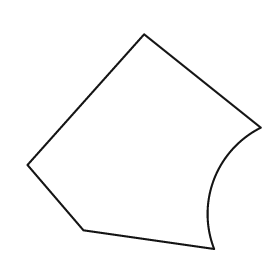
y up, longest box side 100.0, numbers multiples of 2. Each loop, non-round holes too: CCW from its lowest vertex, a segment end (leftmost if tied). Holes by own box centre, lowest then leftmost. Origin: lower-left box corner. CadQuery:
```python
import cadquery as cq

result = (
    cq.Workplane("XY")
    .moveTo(80.0, 0.0)
    .threePointArc((80.0, 30.0), (100.0, 52.0))
    .lineTo(50.0, 92.0)
    .lineTo(0.0, 36.0)
    .lineTo(24.0, 8.0)
    .close()
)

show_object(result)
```